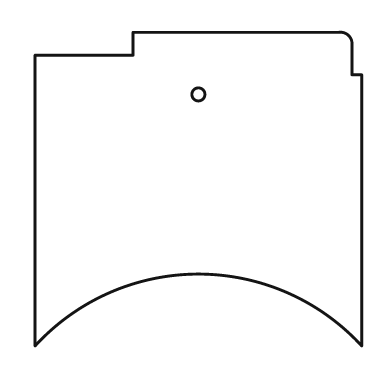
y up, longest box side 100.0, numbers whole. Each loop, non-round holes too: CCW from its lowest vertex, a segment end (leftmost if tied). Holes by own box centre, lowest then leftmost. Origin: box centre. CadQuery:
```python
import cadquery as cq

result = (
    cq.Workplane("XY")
    .moveTo(-50.0, -48.0)
    .threePointArc((0.0, -26.0), (50.0, -48.0))
    .lineTo(50.0, 35.0)
    .lineTo(47.0, 35.0)
    .lineTo(47.0, 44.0)
    .threePointArc((46.0, 47.0), (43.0, 48.0))
    .lineTo(-20.0, 48.0)
    .lineTo(-20.0, 41.0)
    .lineTo(-50.0, 41.0)
    .close()
    .moveTo(0.0, 29.0)
    .circle(2.0)
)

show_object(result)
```